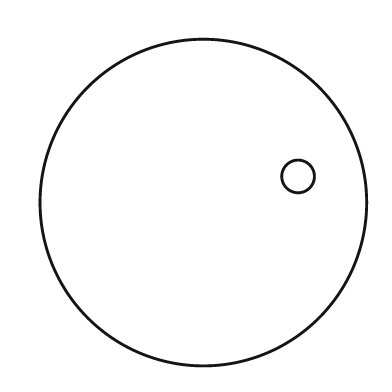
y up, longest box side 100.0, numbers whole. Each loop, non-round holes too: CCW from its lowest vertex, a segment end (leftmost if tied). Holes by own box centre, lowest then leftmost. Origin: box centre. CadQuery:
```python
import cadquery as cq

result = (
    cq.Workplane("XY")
    .moveTo(0.0, 0.0)
    .circle(50.0)
    .moveTo(29.0, 8.0)
    .circle(5.0)
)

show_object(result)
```